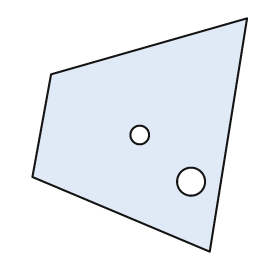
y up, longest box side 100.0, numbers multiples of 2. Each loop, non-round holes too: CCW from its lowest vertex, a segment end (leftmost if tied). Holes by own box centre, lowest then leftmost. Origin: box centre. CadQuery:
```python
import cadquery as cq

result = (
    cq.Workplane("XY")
    .moveTo(30.0, -50.0)
    .lineTo(46.0, 50.0)
    .lineTo(-38.0, 26.0)
    .lineTo(-46.0, -18.0)
    .close()
    .moveTo(22.0, -20.0)
    .circle(6.0)
    .moveTo(0.0, 0.0)
    .circle(4.0)
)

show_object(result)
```